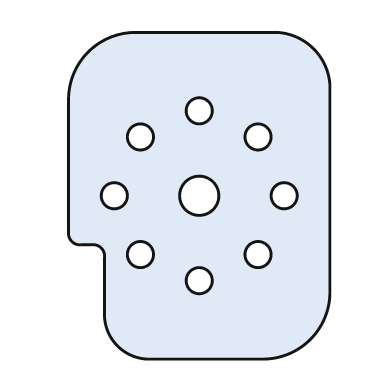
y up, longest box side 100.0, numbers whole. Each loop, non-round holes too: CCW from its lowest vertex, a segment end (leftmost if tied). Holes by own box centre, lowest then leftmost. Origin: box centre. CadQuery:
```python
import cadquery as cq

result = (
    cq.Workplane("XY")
    .moveTo(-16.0, -50.0)
    .lineTo(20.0, -50.0)
    .threePointArc((34.0, -44.0), (40.0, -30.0))
    .lineTo(40.0, 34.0)
    .threePointArc((35.0, 45.0), (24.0, 50.0))
    .lineTo(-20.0, 50.0)
    .threePointArc((-34.0, 44.0), (-40.0, 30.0))
    .lineTo(-40.0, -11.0)
    .threePointArc((-39.0, -14.0), (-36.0, -15.0))
    .lineTo(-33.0, -15.0)
    .threePointArc((-30.0, -16.0), (-29.0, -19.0))
    .lineTo(-29.0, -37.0)
    .threePointArc((-25.0, -46.0), (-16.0, -50.0))
    .close()
    .moveTo(0.0, -26.0)
    .circle(4.0)
    .moveTo(-18.0, -18.0)
    .circle(4.0)
    .moveTo(18.0, -18.0)
    .circle(4.0)
    .moveTo(-26.0, 0.0)
    .circle(4.0)
    .moveTo(0.0, 0.0)
    .circle(6.0)
    .moveTo(26.0, 0.0)
    .circle(4.0)
    .moveTo(-18.0, 18.0)
    .circle(4.0)
    .moveTo(18.0, 18.0)
    .circle(4.0)
    .moveTo(0.0, 26.0)
    .circle(4.0)
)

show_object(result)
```